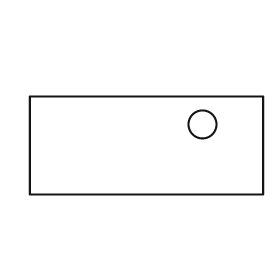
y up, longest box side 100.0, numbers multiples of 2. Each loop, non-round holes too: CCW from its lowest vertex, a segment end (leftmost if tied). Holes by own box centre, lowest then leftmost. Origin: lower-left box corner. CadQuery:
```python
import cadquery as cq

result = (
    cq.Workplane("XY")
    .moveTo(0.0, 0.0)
    .lineTo(100.0, 0.0)
    .lineTo(100.0, 42.0)
    .lineTo(0.0, 42.0)
    .close()
    .moveTo(74.0, 30.0)
    .circle(6.0)
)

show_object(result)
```